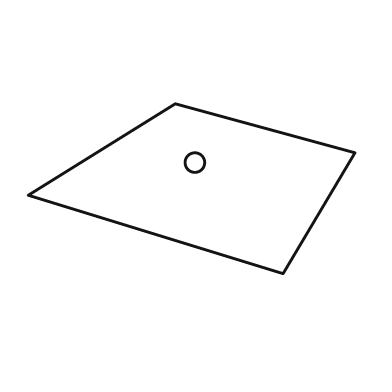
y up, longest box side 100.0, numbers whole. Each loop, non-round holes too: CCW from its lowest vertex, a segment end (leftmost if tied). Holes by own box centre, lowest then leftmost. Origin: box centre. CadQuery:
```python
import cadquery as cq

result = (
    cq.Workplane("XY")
    .moveTo(28.0, -26.0)
    .lineTo(50.0, 11.0)
    .lineTo(-5.0, 26.0)
    .lineTo(-50.0, -2.0)
    .close()
    .moveTo(1.0, 8.0)
    .circle(3.0)
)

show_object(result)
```